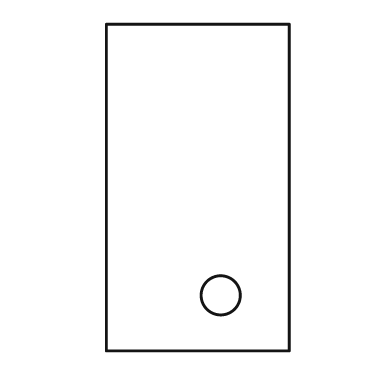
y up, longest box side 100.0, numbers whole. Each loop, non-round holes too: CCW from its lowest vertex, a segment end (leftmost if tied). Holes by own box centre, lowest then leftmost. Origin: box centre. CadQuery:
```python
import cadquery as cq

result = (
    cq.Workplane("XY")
    .moveTo(-28.0, -50.0)
    .lineTo(28.0, -50.0)
    .lineTo(28.0, 50.0)
    .lineTo(-28.0, 50.0)
    .close()
    .moveTo(7.0, -33.0)
    .circle(6.0)
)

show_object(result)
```